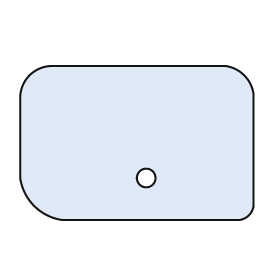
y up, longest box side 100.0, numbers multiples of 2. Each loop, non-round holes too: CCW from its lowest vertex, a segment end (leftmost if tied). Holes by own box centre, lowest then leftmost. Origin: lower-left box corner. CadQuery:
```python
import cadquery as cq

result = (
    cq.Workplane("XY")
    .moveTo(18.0, 0.0)
    .lineTo(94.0, 0.0)
    .threePointArc((98.0, 2.0), (100.0, 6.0))
    .lineTo(100.0, 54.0)
    .threePointArc((96.0, 62.0), (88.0, 66.0))
    .lineTo(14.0, 66.0)
    .threePointArc((4.0, 62.0), (0.0, 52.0))
    .lineTo(0.0, 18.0)
    .threePointArc((6.0, 6.0), (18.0, 0.0))
    .close()
    .moveTo(54.0, 18.0)
    .circle(4.0)
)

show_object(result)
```